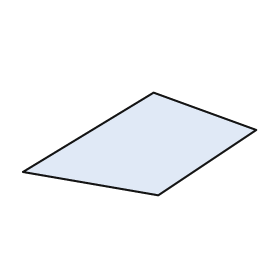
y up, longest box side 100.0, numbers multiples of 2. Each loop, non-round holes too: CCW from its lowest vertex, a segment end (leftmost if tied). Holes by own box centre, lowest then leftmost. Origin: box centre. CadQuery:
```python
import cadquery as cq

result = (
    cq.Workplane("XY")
    .moveTo(8.0, -22.0)
    .lineTo(50.0, 6.0)
    .lineTo(6.0, 22.0)
    .lineTo(-50.0, -12.0)
    .close()
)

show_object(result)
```